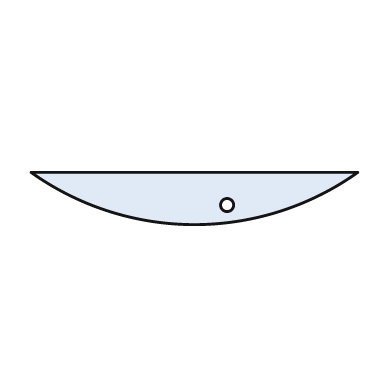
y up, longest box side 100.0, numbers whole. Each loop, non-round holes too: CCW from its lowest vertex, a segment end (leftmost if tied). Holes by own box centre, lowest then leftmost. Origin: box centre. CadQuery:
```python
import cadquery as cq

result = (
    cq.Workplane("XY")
    .moveTo(-50.0, 8.0)
    .threePointArc((0.0, -8.0), (50.0, 8.0))
    .close()
    .moveTo(10.0, -2.0)
    .circle(2.0)
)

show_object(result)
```